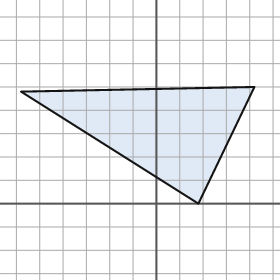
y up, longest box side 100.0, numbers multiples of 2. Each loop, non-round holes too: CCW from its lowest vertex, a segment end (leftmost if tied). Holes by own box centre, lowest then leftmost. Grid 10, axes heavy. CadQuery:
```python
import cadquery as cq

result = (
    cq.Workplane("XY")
    .moveTo(18.0, 0.0)
    .lineTo(42.0, 50.0)
    .lineTo(-58.0, 48.0)
    .close()
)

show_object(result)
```